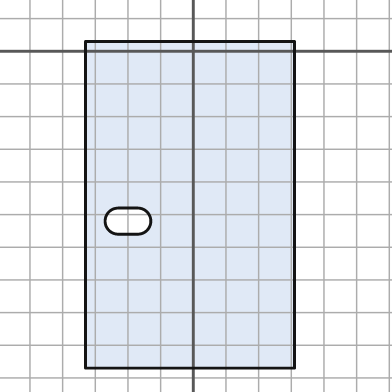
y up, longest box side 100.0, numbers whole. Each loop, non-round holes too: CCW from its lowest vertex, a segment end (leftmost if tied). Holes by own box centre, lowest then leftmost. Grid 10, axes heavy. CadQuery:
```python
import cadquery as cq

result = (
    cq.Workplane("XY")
    .moveTo(-33.0, -97.0)
    .lineTo(31.0, -97.0)
    .lineTo(31.0, 3.0)
    .lineTo(-33.0, 3.0)
    .close()
    .moveTo(-23.0, -56.0)
    .lineTo(-17.0, -56.0)
    .threePointArc((-13.0, -52.0), (-17.0, -48.0))
    .lineTo(-23.0, -48.0)
    .threePointArc((-27.0, -52.0), (-23.0, -56.0))
    .close()
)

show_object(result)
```